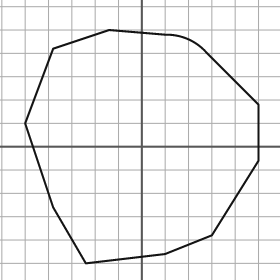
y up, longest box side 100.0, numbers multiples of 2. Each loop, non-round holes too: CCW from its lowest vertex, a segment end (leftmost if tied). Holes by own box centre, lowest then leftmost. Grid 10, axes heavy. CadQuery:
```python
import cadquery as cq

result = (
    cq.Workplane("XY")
    .moveTo(-24.0, -50.0)
    .lineTo(10.0, -46.0)
    .lineTo(30.0, -38.0)
    .lineTo(50.0, -6.0)
    .lineTo(50.0, 18.0)
    .lineTo(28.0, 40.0)
    .threePointArc((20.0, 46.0), (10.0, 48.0))
    .lineTo(-14.0, 50.0)
    .lineTo(-38.0, 42.0)
    .lineTo(-50.0, 10.0)
    .lineTo(-38.0, -26.0)
    .close()
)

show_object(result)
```